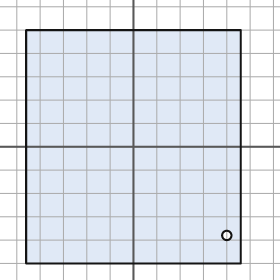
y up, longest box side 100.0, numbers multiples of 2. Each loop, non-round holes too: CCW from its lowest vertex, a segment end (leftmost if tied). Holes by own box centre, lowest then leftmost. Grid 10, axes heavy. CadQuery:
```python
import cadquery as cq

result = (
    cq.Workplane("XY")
    .moveTo(-46.0, -50.0)
    .lineTo(46.0, -50.0)
    .lineTo(46.0, 50.0)
    .lineTo(-46.0, 50.0)
    .close()
    .moveTo(40.0, -38.0)
    .circle(2.0)
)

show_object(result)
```